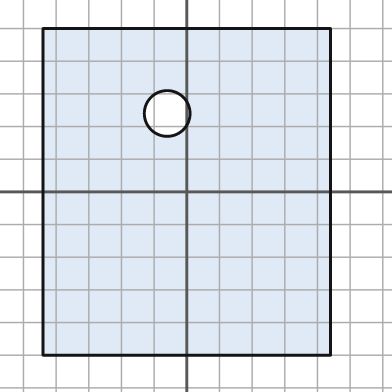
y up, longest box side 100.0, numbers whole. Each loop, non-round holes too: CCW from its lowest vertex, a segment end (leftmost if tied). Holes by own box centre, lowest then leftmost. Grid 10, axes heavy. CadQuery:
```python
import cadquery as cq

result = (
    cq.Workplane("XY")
    .moveTo(-44.0, -50.0)
    .lineTo(44.0, -50.0)
    .lineTo(44.0, 50.0)
    .lineTo(-44.0, 50.0)
    .close()
    .moveTo(-6.0, 24.0)
    .circle(7.0)
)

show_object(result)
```